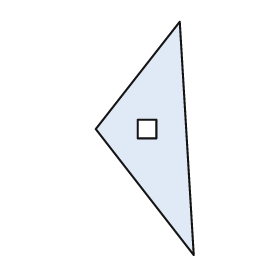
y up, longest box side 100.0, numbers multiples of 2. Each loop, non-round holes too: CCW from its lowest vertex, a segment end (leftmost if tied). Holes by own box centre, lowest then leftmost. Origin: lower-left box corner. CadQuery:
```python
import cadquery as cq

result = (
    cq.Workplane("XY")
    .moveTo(42.0, 0.0)
    .lineTo(36.0, 100.0)
    .lineTo(0.0, 54.0)
    .close()
    .moveTo(18.0, 50.0)
    .lineTo(26.0, 50.0)
    .lineTo(26.0, 58.0)
    .lineTo(18.0, 58.0)
    .close()
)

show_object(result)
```